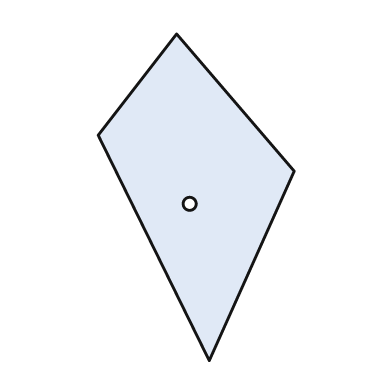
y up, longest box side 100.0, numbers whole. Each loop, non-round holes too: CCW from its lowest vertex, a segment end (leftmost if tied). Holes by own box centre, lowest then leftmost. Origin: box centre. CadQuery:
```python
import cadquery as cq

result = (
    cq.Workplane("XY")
    .moveTo(4.0, -50.0)
    .lineTo(30.0, 8.0)
    .lineTo(-6.0, 50.0)
    .lineTo(-30.0, 19.0)
    .close()
    .moveTo(-2.0, -2.0)
    .circle(2.0)
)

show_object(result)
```